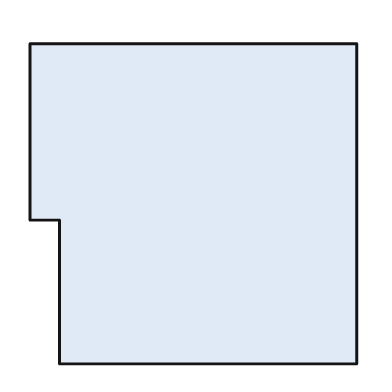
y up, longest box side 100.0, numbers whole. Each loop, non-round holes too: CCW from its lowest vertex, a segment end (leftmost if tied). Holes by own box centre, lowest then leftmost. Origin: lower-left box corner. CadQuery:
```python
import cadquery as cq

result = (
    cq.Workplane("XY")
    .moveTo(9.0, 0.0)
    .lineTo(100.0, 0.0)
    .lineTo(100.0, 98.0)
    .lineTo(0.0, 98.0)
    .lineTo(0.0, 44.0)
    .lineTo(9.0, 44.0)
    .close()
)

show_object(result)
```